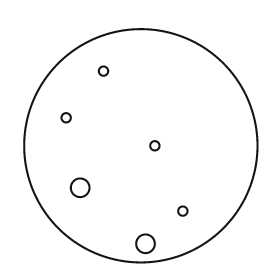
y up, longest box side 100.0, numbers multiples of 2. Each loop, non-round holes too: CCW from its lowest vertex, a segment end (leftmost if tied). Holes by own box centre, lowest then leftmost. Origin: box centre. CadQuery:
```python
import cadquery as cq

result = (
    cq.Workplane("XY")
    .moveTo(0.0, 0.0)
    .circle(50.0)
    .moveTo(2.0, -42.0)
    .circle(4.0)
    .moveTo(18.0, -28.0)
    .circle(2.0)
    .moveTo(-26.0, -18.0)
    .circle(4.0)
    .moveTo(6.0, 0.0)
    .circle(2.0)
    .moveTo(-32.0, 12.0)
    .circle(2.0)
    .moveTo(-16.0, 32.0)
    .circle(2.0)
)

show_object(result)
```